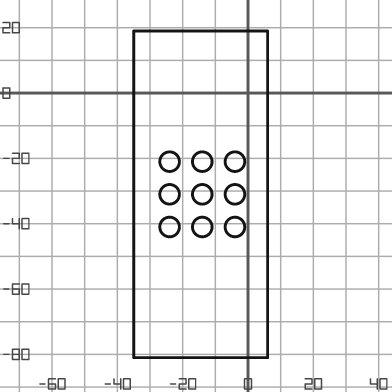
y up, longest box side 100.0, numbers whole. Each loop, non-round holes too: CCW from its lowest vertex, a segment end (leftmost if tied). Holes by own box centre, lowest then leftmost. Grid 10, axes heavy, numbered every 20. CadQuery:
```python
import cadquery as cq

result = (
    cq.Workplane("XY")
    .moveTo(-35.0, -81.0)
    .lineTo(6.0, -81.0)
    .lineTo(6.0, 19.0)
    .lineTo(-35.0, 19.0)
    .close()
    .moveTo(-24.0, -41.0)
    .circle(3.0)
    .moveTo(-14.0, -41.0)
    .circle(3.0)
    .moveTo(-4.0, -41.0)
    .circle(3.0)
    .moveTo(-24.0, -31.0)
    .circle(3.0)
    .moveTo(-14.0, -31.0)
    .circle(3.0)
    .moveTo(-4.0, -31.0)
    .circle(3.0)
    .moveTo(-24.0, -21.0)
    .circle(3.0)
    .moveTo(-14.0, -21.0)
    .circle(3.0)
    .moveTo(-4.0, -21.0)
    .circle(3.0)
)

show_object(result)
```